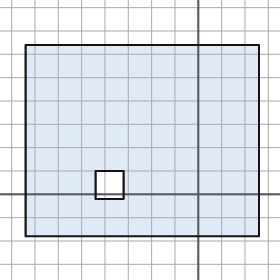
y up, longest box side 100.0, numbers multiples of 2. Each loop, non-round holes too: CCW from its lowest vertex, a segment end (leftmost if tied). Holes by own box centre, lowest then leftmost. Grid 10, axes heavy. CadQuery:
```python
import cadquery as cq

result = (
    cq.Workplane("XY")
    .moveTo(-74.0, -18.0)
    .lineTo(26.0, -18.0)
    .lineTo(26.0, 64.0)
    .lineTo(-74.0, 64.0)
    .close()
    .moveTo(-44.0, -2.0)
    .lineTo(-32.0, -2.0)
    .lineTo(-32.0, 10.0)
    .lineTo(-44.0, 10.0)
    .close()
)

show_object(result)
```